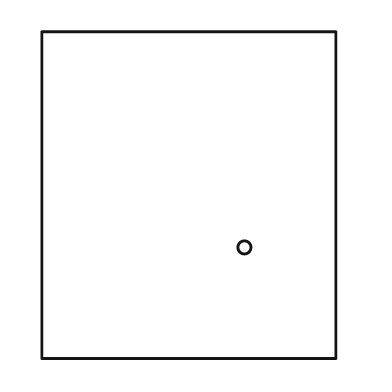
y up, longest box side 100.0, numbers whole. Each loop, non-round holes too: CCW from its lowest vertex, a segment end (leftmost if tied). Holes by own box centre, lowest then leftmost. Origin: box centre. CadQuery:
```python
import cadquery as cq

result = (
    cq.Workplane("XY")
    .moveTo(-45.0, -50.0)
    .lineTo(45.0, -50.0)
    .lineTo(45.0, 50.0)
    .lineTo(-45.0, 50.0)
    .close()
    .moveTo(17.0, -16.0)
    .circle(2.0)
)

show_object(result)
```